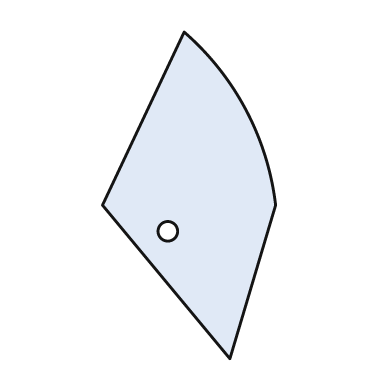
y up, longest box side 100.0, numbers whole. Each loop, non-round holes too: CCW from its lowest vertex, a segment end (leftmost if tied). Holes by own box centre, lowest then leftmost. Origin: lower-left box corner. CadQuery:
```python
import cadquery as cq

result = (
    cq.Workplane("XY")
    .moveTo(39.0, 0.0)
    .lineTo(53.0, 47.0)
    .threePointArc((44.0, 76.0), (25.0, 100.0))
    .lineTo(0.0, 47.0)
    .close()
    .moveTo(20.0, 39.0)
    .circle(3.0)
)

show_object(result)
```